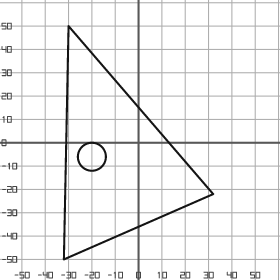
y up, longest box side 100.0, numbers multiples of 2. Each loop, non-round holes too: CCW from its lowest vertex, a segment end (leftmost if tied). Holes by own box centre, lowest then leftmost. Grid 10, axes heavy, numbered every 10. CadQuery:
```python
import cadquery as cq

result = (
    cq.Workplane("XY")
    .moveTo(-32.0, -50.0)
    .lineTo(32.0, -22.0)
    .lineTo(-30.0, 50.0)
    .close()
    .moveTo(-20.0, -6.0)
    .circle(6.0)
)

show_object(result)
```